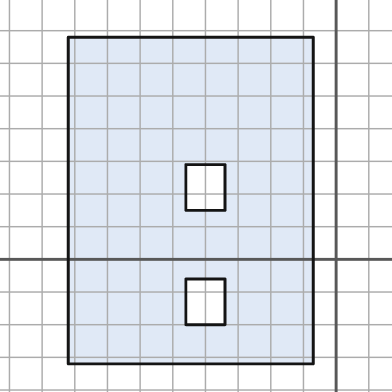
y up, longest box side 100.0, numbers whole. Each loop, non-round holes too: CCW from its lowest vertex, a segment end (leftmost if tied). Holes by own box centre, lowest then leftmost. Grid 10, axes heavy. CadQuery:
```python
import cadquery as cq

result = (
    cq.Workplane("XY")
    .moveTo(-82.0, -32.0)
    .lineTo(-7.0, -32.0)
    .lineTo(-7.0, 68.0)
    .lineTo(-82.0, 68.0)
    .close()
    .moveTo(-46.0, -20.0)
    .lineTo(-34.0, -20.0)
    .lineTo(-34.0, -6.0)
    .lineTo(-46.0, -6.0)
    .close()
    .moveTo(-46.0, 15.0)
    .lineTo(-34.0, 15.0)
    .lineTo(-34.0, 29.0)
    .lineTo(-46.0, 29.0)
    .close()
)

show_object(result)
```